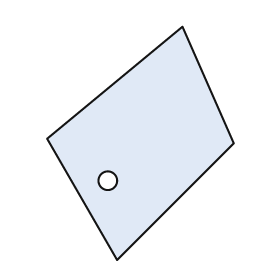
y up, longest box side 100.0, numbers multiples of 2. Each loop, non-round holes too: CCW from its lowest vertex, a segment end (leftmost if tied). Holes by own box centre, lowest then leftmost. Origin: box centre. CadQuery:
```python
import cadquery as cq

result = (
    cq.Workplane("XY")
    .moveTo(-10.0, -50.0)
    .lineTo(40.0, 0.0)
    .lineTo(18.0, 50.0)
    .lineTo(-40.0, 2.0)
    .close()
    .moveTo(-14.0, -16.0)
    .circle(4.0)
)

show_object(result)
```